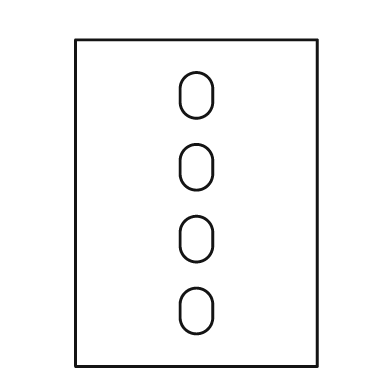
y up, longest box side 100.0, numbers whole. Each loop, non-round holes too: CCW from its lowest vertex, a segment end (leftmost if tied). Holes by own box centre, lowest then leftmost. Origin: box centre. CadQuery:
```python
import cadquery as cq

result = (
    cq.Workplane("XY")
    .moveTo(-37.0, -50.0)
    .lineTo(37.0, -50.0)
    .lineTo(37.0, 50.0)
    .lineTo(-37.0, 50.0)
    .close()
    .moveTo(-5.0, -35.0)
    .threePointArc((0.0, -40.0), (5.0, -35.0))
    .lineTo(5.0, -31.0)
    .threePointArc((0.0, -26.0), (-5.0, -31.0))
    .close()
    .moveTo(-5.0, -13.0)
    .threePointArc((0.0, -18.0), (5.0, -13.0))
    .lineTo(5.0, -9.0)
    .threePointArc((0.0, -4.0), (-5.0, -9.0))
    .close()
    .moveTo(-5.0, 9.0)
    .threePointArc((0.0, 4.0), (5.0, 9.0))
    .lineTo(5.0, 13.0)
    .threePointArc((0.0, 18.0), (-5.0, 13.0))
    .close()
    .moveTo(-5.0, 31.0)
    .threePointArc((0.0, 26.0), (5.0, 31.0))
    .lineTo(5.0, 35.0)
    .threePointArc((0.0, 40.0), (-5.0, 35.0))
    .close()
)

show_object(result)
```